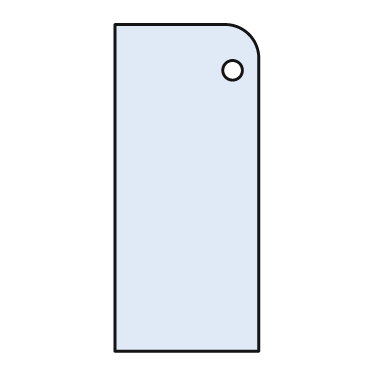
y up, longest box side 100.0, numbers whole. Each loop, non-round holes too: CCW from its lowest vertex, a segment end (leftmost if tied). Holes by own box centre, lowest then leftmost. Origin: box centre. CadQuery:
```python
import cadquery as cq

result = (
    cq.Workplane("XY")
    .moveTo(-22.0, -50.0)
    .lineTo(22.0, -50.0)
    .lineTo(22.0, 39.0)
    .threePointArc((19.0, 47.0), (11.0, 50.0))
    .lineTo(-22.0, 50.0)
    .close()
    .moveTo(14.0, 36.0)
    .circle(3.0)
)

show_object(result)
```